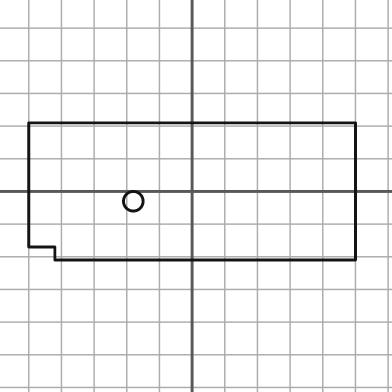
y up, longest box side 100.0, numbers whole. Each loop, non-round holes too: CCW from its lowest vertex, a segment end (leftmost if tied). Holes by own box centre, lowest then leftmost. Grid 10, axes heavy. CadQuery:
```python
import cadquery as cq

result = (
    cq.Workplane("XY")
    .moveTo(-42.0, -21.0)
    .lineTo(50.0, -21.0)
    .lineTo(50.0, 21.0)
    .lineTo(-50.0, 21.0)
    .lineTo(-50.0, -17.0)
    .lineTo(-42.0, -17.0)
    .close()
    .moveTo(-18.0, -3.0)
    .circle(3.0)
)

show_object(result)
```